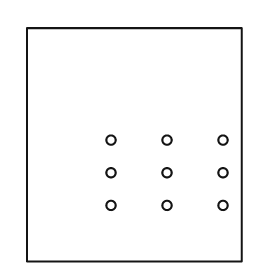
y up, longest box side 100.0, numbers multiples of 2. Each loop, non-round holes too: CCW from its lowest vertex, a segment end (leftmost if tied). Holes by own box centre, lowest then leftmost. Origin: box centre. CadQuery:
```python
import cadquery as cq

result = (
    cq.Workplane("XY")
    .moveTo(-46.0, -50.0)
    .lineTo(46.0, -50.0)
    .lineTo(46.0, 50.0)
    .lineTo(-46.0, 50.0)
    .close()
    .moveTo(-10.0, -26.0)
    .circle(2.0)
    .moveTo(14.0, -26.0)
    .circle(2.0)
    .moveTo(38.0, -26.0)
    .circle(2.0)
    .moveTo(-10.0, -12.0)
    .circle(2.0)
    .moveTo(14.0, -12.0)
    .circle(2.0)
    .moveTo(38.0, -12.0)
    .circle(2.0)
    .moveTo(-10.0, 2.0)
    .circle(2.0)
    .moveTo(14.0, 2.0)
    .circle(2.0)
    .moveTo(38.0, 2.0)
    .circle(2.0)
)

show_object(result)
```